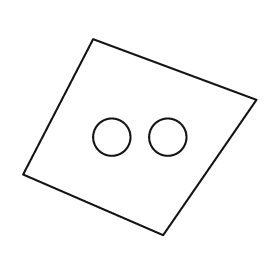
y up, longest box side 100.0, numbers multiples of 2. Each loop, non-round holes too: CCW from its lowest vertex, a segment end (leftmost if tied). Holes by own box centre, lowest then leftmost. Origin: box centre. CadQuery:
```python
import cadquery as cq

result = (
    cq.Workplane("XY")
    .moveTo(10.0, -42.0)
    .lineTo(50.0, 16.0)
    .lineTo(-20.0, 42.0)
    .lineTo(-50.0, -16.0)
    .close()
    .moveTo(-12.0, 0.0)
    .circle(8.0)
    .moveTo(12.0, 0.0)
    .circle(8.0)
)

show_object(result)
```